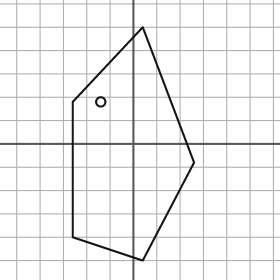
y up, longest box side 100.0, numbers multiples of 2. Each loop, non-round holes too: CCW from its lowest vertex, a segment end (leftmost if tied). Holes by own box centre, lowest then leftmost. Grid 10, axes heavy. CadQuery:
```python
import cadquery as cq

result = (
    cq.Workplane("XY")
    .moveTo(4.0, -50.0)
    .lineTo(26.0, -8.0)
    .lineTo(4.0, 50.0)
    .lineTo(-26.0, 18.0)
    .lineTo(-26.0, -40.0)
    .close()
    .moveTo(-14.0, 18.0)
    .circle(2.0)
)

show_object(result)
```